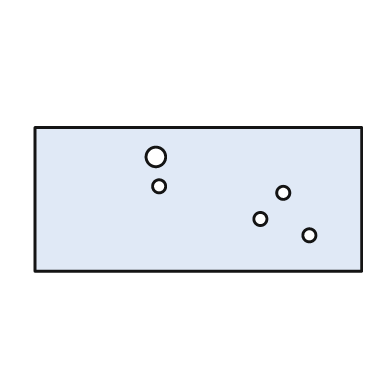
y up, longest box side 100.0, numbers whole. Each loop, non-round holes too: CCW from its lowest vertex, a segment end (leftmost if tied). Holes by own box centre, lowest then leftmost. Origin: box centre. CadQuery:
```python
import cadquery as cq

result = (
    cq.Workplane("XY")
    .moveTo(-50.0, -22.0)
    .lineTo(50.0, -22.0)
    .lineTo(50.0, 22.0)
    .lineTo(-50.0, 22.0)
    .close()
    .moveTo(34.0, -11.0)
    .circle(2.0)
    .moveTo(19.0, -6.0)
    .circle(2.0)
    .moveTo(26.0, 2.0)
    .circle(2.0)
    .moveTo(-12.0, 4.0)
    .circle(2.0)
    .moveTo(-13.0, 13.0)
    .circle(3.0)
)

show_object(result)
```